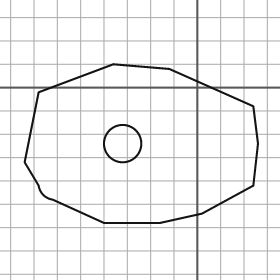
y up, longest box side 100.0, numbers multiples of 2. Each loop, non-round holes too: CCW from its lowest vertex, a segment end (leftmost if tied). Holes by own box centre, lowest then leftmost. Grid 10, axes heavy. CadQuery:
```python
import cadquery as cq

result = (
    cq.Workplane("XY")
    .moveTo(-40.0, -58.0)
    .lineTo(-16.0, -58.0)
    .lineTo(2.0, -54.0)
    .lineTo(24.0, -42.0)
    .lineTo(26.0, -24.0)
    .lineTo(24.0, -8.0)
    .lineTo(-12.0, 8.0)
    .lineTo(-36.0, 10.0)
    .lineTo(-68.0, -2.0)
    .lineTo(-74.0, -32.0)
    .lineTo(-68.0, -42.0)
    .threePointArc((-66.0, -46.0), (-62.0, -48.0))
    .close()
    .moveTo(-32.0, -24.0)
    .circle(8.0)
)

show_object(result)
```